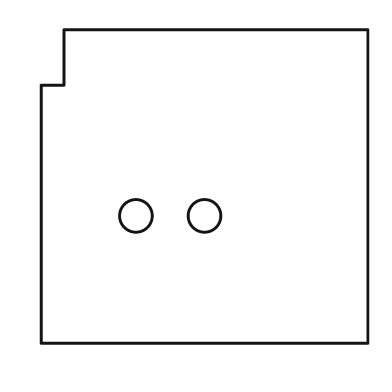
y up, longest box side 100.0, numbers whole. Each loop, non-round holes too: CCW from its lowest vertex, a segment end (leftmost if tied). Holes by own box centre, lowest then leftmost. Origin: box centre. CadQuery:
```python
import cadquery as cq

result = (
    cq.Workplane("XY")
    .moveTo(-50.0, -48.0)
    .lineTo(50.0, -48.0)
    .lineTo(50.0, 48.0)
    .lineTo(-43.0, 48.0)
    .lineTo(-43.0, 31.0)
    .lineTo(-50.0, 31.0)
    .close()
    .moveTo(-21.0, -9.0)
    .circle(5.0)
    .moveTo(0.0, -9.0)
    .circle(5.0)
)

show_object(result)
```